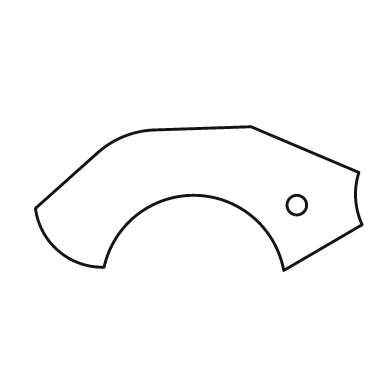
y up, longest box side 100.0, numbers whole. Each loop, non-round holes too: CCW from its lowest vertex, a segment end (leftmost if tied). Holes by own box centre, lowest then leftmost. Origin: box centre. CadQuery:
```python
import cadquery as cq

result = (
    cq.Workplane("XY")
    .moveTo(26.0, -22.0)
    .lineTo(50.0, -8.0)
    .threePointArc((48.0, 0.0), (49.0, 8.0))
    .lineTo(16.0, 22.0)
    .lineTo(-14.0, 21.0)
    .threePointArc((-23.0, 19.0), (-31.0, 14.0))
    .lineTo(-50.0, -3.0)
    .threePointArc((-43.0, -16.0), (-29.0, -21.0))
    .threePointArc((-1.0, 1.0), (26.0, -22.0))
    .close()
    .moveTo(30.0, -2.0)
    .circle(3.0)
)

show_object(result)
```